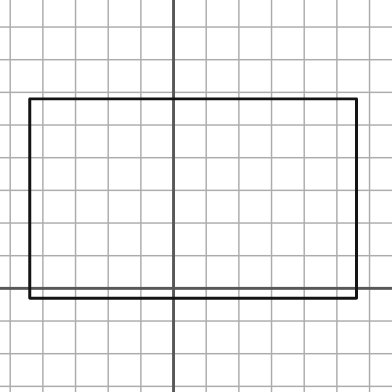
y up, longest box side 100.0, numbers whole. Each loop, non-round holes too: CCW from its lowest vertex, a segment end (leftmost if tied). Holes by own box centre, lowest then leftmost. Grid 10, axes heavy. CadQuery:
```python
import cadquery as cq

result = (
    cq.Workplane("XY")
    .moveTo(-44.0, -3.0)
    .lineTo(56.0, -3.0)
    .lineTo(56.0, 58.0)
    .lineTo(-44.0, 58.0)
    .close()
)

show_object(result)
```